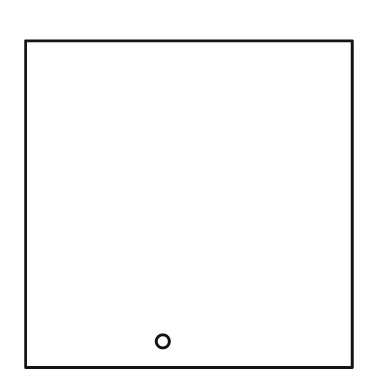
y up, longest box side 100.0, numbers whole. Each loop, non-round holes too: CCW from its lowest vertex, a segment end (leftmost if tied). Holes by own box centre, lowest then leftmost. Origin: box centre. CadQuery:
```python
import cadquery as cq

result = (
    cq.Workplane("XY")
    .moveTo(-50.0, -50.0)
    .lineTo(50.0, -50.0)
    .lineTo(50.0, 50.0)
    .lineTo(-50.0, 50.0)
    .close()
    .moveTo(-8.0, -42.0)
    .circle(2.0)
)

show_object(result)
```